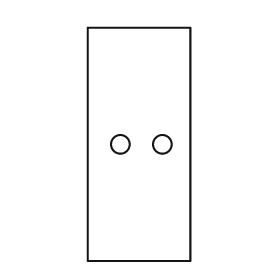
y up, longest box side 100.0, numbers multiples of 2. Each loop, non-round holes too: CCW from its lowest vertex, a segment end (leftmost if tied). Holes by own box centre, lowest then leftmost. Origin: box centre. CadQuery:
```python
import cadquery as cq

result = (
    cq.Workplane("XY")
    .moveTo(-22.0, -50.0)
    .lineTo(22.0, -50.0)
    .lineTo(22.0, 50.0)
    .lineTo(-22.0, 50.0)
    .close()
    .moveTo(-8.0, 0.0)
    .circle(4.0)
    .moveTo(10.0, 0.0)
    .circle(4.0)
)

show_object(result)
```